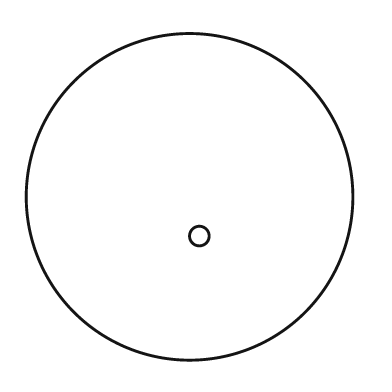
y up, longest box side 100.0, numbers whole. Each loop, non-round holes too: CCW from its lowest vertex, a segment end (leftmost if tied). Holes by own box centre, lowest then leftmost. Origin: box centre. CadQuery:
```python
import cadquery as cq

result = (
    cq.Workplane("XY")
    .moveTo(0.0, 0.0)
    .circle(50.0)
    .moveTo(3.0, -12.0)
    .circle(3.0)
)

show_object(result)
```